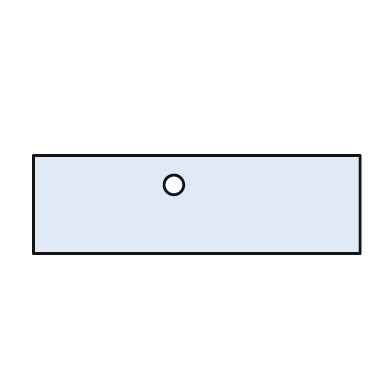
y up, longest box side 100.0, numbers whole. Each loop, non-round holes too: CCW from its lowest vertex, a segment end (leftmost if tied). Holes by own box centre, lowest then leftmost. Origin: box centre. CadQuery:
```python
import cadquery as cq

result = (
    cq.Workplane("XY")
    .moveTo(-50.0, -15.0)
    .lineTo(50.0, -15.0)
    .lineTo(50.0, 15.0)
    .lineTo(-50.0, 15.0)
    .close()
    .moveTo(-7.0, 6.0)
    .circle(3.0)
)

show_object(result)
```